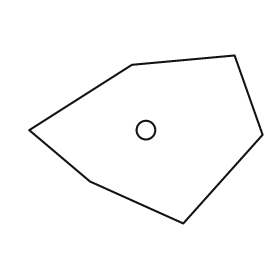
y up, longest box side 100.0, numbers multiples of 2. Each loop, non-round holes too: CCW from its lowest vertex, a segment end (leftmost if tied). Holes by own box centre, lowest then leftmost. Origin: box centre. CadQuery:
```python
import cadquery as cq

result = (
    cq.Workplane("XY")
    .moveTo(16.0, -36.0)
    .lineTo(50.0, 2.0)
    .lineTo(38.0, 36.0)
    .lineTo(-6.0, 32.0)
    .lineTo(-50.0, 4.0)
    .lineTo(-24.0, -18.0)
    .close()
    .moveTo(0.0, 4.0)
    .circle(4.0)
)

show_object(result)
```